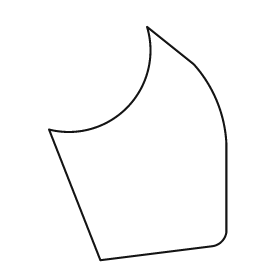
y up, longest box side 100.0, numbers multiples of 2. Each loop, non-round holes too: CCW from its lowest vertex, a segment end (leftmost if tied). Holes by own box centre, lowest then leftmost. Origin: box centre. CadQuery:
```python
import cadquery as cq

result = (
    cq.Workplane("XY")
    .moveTo(-16.0, -50.0)
    .lineTo(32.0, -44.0)
    .threePointArc((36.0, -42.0), (38.0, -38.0))
    .lineTo(38.0, 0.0)
    .threePointArc((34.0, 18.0), (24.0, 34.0))
    .lineTo(4.0, 50.0)
    .threePointArc((-4.0, 16.0), (-38.0, 6.0))
    .close()
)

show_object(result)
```